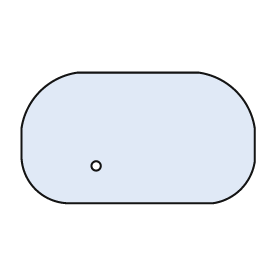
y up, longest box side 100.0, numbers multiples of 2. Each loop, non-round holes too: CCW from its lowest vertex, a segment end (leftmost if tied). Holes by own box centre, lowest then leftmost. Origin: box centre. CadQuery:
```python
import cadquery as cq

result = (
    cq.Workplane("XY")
    .moveTo(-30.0, -28.0)
    .lineTo(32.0, -28.0)
    .threePointArc((44.0, -22.0), (50.0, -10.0))
    .lineTo(50.0, 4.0)
    .threePointArc((42.0, 20.0), (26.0, 28.0))
    .lineTo(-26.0, 28.0)
    .threePointArc((-42.0, 20.0), (-50.0, 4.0))
    .lineTo(-50.0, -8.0)
    .threePointArc((-44.0, -22.0), (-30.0, -28.0))
    .close()
    .moveTo(-18.0, -12.0)
    .circle(2.0)
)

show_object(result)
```